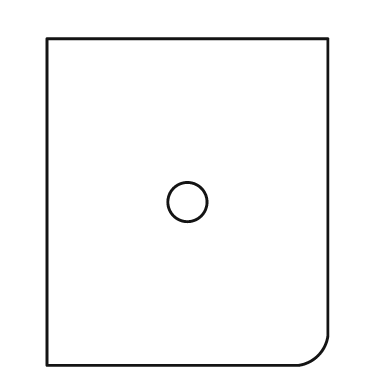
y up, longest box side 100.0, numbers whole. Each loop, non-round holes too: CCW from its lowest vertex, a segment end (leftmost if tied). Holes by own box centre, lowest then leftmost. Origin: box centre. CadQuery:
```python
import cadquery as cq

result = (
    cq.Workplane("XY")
    .moveTo(-43.0, -50.0)
    .lineTo(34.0, -50.0)
    .threePointArc((40.0, -47.0), (43.0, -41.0))
    .lineTo(43.0, 50.0)
    .lineTo(-43.0, 50.0)
    .close()
    .moveTo(0.0, 0.0)
    .circle(6.0)
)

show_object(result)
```